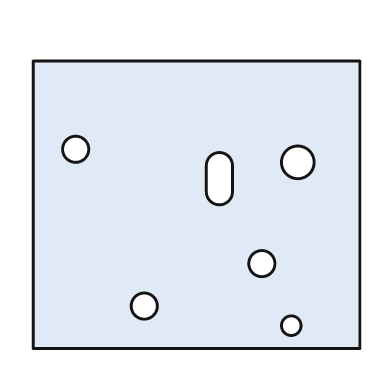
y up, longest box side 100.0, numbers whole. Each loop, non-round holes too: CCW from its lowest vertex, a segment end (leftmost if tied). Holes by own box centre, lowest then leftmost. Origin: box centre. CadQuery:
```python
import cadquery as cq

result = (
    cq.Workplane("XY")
    .moveTo(-50.0, -44.0)
    .lineTo(50.0, -44.0)
    .lineTo(50.0, 44.0)
    .lineTo(-50.0, 44.0)
    .close()
    .moveTo(29.0, -37.0)
    .circle(3.0)
    .moveTo(-16.0, -31.0)
    .circle(4.0)
    .moveTo(20.0, -18.0)
    .circle(4.0)
    .moveTo(3.0, 4.0)
    .threePointArc((7.0, 0.0), (11.0, 4.0))
    .lineTo(11.0, 12.0)
    .threePointArc((7.0, 16.0), (3.0, 12.0))
    .close()
    .moveTo(31.0, 13.0)
    .circle(5.0)
    .moveTo(-37.0, 17.0)
    .circle(4.0)
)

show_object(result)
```